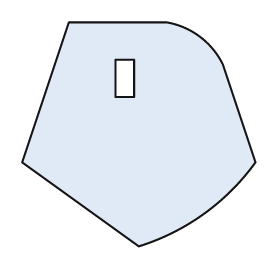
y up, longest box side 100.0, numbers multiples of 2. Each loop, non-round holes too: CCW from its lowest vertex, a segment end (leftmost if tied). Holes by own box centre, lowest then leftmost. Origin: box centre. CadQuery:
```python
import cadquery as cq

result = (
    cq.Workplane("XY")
    .moveTo(0.0, -48.0)
    .threePointArc((28.0, -34.0), (50.0, -12.0))
    .lineTo(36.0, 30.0)
    .threePointArc((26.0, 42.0), (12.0, 48.0))
    .lineTo(-30.0, 48.0)
    .lineTo(-50.0, -12.0)
    .close()
    .moveTo(-10.0, 16.0)
    .lineTo(-2.0, 16.0)
    .lineTo(-2.0, 32.0)
    .lineTo(-10.0, 32.0)
    .close()
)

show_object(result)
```